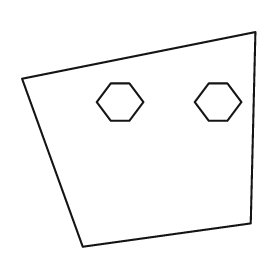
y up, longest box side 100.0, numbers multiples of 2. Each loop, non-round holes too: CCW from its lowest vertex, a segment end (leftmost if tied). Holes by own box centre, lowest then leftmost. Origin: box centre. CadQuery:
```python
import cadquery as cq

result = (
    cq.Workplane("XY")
    .moveTo(-24.0, -46.0)
    .lineTo(48.0, -36.0)
    .lineTo(50.0, 46.0)
    .lineTo(-50.0, 26.0)
    .close()
    .moveTo(-12.0, 8.0)
    .lineTo(-4.0, 8.0)
    .lineTo(2.0, 16.0)
    .lineTo(-4.0, 24.0)
    .lineTo(-12.0, 24.0)
    .lineTo(-18.0, 16.0)
    .close()
    .moveTo(30.0, 8.0)
    .lineTo(38.0, 8.0)
    .lineTo(44.0, 16.0)
    .lineTo(38.0, 24.0)
    .lineTo(30.0, 24.0)
    .lineTo(24.0, 16.0)
    .close()
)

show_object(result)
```